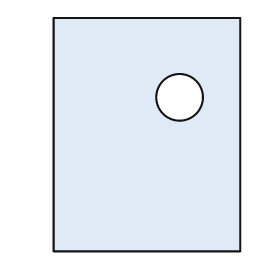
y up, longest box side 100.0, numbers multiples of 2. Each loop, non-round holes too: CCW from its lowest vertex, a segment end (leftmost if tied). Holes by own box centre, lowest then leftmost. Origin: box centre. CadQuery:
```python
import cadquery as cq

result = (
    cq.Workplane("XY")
    .moveTo(-40.0, -50.0)
    .lineTo(40.0, -50.0)
    .lineTo(40.0, 50.0)
    .lineTo(-40.0, 50.0)
    .close()
    .moveTo(14.0, 16.0)
    .circle(10.0)
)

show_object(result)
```